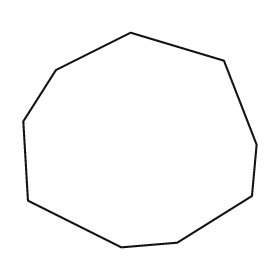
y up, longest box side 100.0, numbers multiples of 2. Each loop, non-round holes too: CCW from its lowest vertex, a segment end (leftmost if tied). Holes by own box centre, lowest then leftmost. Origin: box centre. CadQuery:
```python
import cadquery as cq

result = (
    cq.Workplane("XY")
    .moveTo(-8.0, -46.0)
    .lineTo(16.0, -44.0)
    .lineTo(48.0, -24.0)
    .lineTo(50.0, -2.0)
    .lineTo(36.0, 34.0)
    .lineTo(-4.0, 46.0)
    .lineTo(-36.0, 30.0)
    .lineTo(-50.0, 8.0)
    .lineTo(-48.0, -26.0)
    .close()
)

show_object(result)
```